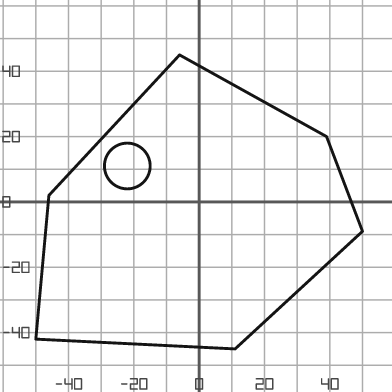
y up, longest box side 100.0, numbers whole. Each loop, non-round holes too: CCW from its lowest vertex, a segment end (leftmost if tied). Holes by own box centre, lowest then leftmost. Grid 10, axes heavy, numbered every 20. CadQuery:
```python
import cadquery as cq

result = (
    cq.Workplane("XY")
    .moveTo(11.0, -45.0)
    .lineTo(50.0, -9.0)
    .lineTo(39.0, 20.0)
    .lineTo(-6.0, 45.0)
    .lineTo(-46.0, 2.0)
    .lineTo(-50.0, -42.0)
    .close()
    .moveTo(-22.0, 11.0)
    .circle(7.0)
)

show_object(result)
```